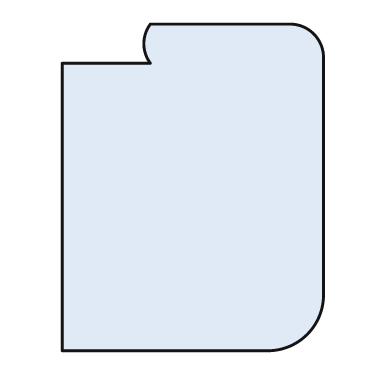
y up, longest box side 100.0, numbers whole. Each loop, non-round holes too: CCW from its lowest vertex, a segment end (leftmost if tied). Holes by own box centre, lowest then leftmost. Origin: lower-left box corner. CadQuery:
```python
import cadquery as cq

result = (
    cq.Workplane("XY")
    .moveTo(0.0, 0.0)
    .lineTo(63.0, 0.0)
    .threePointArc((75.0, 5.0), (80.0, 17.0))
    .lineTo(80.0, 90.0)
    .threePointArc((77.0, 97.0), (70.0, 100.0))
    .lineTo(27.0, 100.0)
    .threePointArc((25.0, 94.0), (27.0, 88.0))
    .lineTo(0.0, 88.0)
    .close()
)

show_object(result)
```